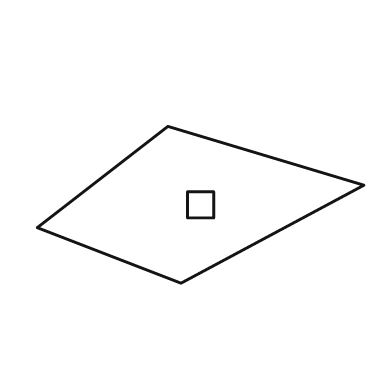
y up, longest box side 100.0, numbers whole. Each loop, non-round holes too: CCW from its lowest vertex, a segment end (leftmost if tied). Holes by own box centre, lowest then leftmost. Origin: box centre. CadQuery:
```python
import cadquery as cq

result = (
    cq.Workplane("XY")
    .moveTo(-6.0, -24.0)
    .lineTo(50.0, 6.0)
    .lineTo(-10.0, 24.0)
    .lineTo(-50.0, -7.0)
    .close()
    .moveTo(-4.0, -4.0)
    .lineTo(4.0, -4.0)
    .lineTo(4.0, 4.0)
    .lineTo(-4.0, 4.0)
    .close()
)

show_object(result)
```